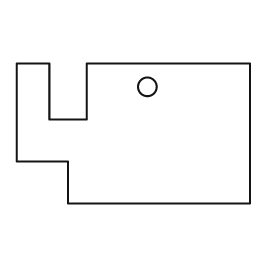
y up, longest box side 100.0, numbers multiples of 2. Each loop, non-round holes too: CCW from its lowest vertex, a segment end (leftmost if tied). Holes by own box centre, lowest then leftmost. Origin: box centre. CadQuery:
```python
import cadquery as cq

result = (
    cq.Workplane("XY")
    .moveTo(-28.0, -30.0)
    .lineTo(50.0, -30.0)
    .lineTo(50.0, 30.0)
    .lineTo(-20.0, 30.0)
    .lineTo(-20.0, 6.0)
    .lineTo(-36.0, 6.0)
    .lineTo(-36.0, 30.0)
    .lineTo(-50.0, 30.0)
    .lineTo(-50.0, -12.0)
    .lineTo(-28.0, -12.0)
    .close()
    .moveTo(6.0, 20.0)
    .circle(4.0)
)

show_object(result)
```